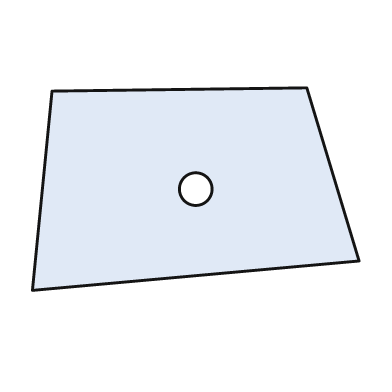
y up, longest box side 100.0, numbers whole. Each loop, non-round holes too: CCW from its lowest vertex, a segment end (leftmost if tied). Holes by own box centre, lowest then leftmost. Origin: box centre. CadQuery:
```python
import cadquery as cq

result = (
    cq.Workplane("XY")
    .moveTo(-50.0, -31.0)
    .lineTo(50.0, -22.0)
    .lineTo(34.0, 31.0)
    .lineTo(-44.0, 30.0)
    .close()
    .moveTo(0.0, 0.0)
    .circle(5.0)
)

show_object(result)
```